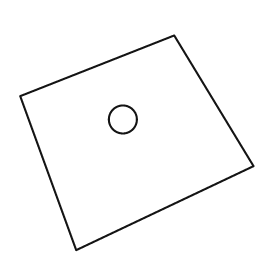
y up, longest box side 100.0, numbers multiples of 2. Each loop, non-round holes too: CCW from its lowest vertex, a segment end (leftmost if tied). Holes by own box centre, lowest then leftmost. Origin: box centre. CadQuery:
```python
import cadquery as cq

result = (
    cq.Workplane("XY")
    .moveTo(-26.0, -46.0)
    .lineTo(50.0, -10.0)
    .lineTo(16.0, 46.0)
    .lineTo(-50.0, 20.0)
    .close()
    .moveTo(-6.0, 10.0)
    .circle(6.0)
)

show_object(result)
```